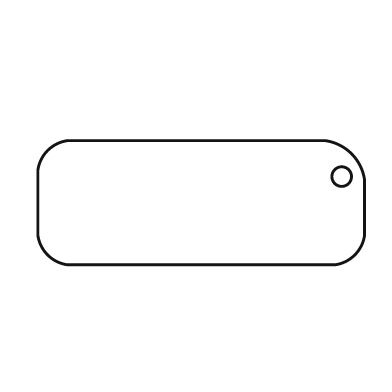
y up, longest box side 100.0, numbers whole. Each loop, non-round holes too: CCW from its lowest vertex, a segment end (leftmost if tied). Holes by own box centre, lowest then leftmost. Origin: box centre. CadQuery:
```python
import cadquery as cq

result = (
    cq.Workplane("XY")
    .moveTo(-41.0, -19.0)
    .lineTo(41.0, -19.0)
    .threePointArc((47.0, -16.0), (50.0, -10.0))
    .lineTo(50.0, 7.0)
    .threePointArc((46.0, 15.0), (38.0, 19.0))
    .lineTo(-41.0, 19.0)
    .threePointArc((-47.0, 16.0), (-50.0, 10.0))
    .lineTo(-50.0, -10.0)
    .threePointArc((-47.0, -16.0), (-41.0, -19.0))
    .close()
    .moveTo(43.0, 8.0)
    .circle(3.0)
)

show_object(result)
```